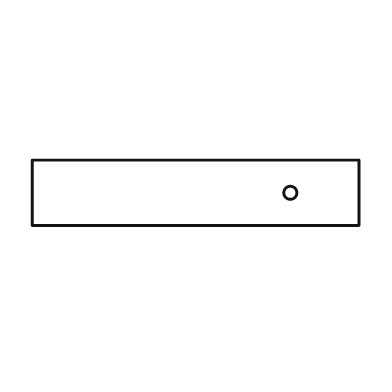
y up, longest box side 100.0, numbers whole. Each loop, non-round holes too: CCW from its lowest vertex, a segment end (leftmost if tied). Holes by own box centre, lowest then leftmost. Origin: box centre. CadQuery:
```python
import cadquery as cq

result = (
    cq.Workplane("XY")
    .moveTo(-50.0, -10.0)
    .lineTo(50.0, -10.0)
    .lineTo(50.0, 10.0)
    .lineTo(-50.0, 10.0)
    .close()
    .moveTo(29.0, 0.0)
    .circle(2.0)
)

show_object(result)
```